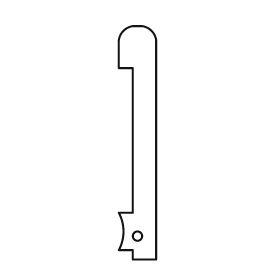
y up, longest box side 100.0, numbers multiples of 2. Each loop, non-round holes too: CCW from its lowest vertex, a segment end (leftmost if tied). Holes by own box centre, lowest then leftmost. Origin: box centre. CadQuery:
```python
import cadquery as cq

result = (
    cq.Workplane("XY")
    .moveTo(-2.0, -50.0)
    .lineTo(8.0, -50.0)
    .lineTo(8.0, 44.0)
    .threePointArc((6.0, 48.0), (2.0, 50.0))
    .lineTo(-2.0, 50.0)
    .threePointArc((-6.0, 48.0), (-8.0, 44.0))
    .lineTo(-8.0, 32.0)
    .lineTo(-2.0, 32.0)
    .lineTo(-2.0, -30.0)
    .lineTo(-8.0, -30.0)
    .threePointArc((-6.0, -38.0), (-8.0, -46.0))
    .lineTo(-2.0, -46.0)
    .close()
    .moveTo(0.0, -40.0)
    .circle(2.0)
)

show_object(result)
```